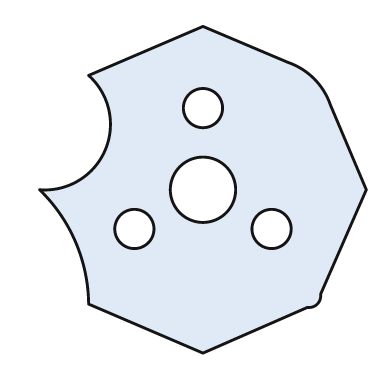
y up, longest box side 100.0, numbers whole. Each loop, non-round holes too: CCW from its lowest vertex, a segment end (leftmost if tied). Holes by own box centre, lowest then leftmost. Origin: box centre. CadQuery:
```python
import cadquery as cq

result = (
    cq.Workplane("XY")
    .moveTo(0.0, -50.0)
    .lineTo(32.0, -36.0)
    .threePointArc((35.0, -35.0), (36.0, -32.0))
    .lineTo(50.0, 0.0)
    .lineTo(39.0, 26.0)
    .threePointArc((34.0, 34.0), (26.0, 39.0))
    .lineTo(0.0, 50.0)
    .lineTo(-35.0, 35.0)
    .threePointArc((-30.0, 12.0), (-50.0, 0.0))
    .threePointArc((-39.0, -16.0), (-35.0, -35.0))
    .close()
    .moveTo(-21.0, -12.0)
    .circle(6.0)
    .moveTo(21.0, -12.0)
    .circle(6.0)
    .moveTo(0.0, 0.0)
    .circle(10.0)
    .moveTo(0.0, 25.0)
    .circle(6.0)
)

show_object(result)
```